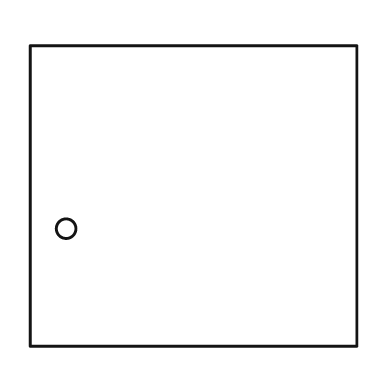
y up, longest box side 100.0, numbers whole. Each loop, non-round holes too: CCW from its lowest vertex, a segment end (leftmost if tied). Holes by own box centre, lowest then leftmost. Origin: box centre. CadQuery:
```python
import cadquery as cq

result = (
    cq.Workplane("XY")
    .moveTo(-50.0, -46.0)
    .lineTo(50.0, -46.0)
    .lineTo(50.0, 46.0)
    .lineTo(-50.0, 46.0)
    .close()
    .moveTo(-39.0, -10.0)
    .circle(3.0)
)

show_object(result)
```